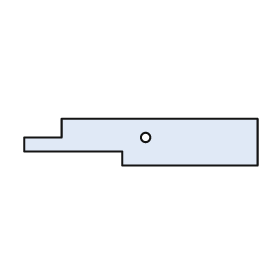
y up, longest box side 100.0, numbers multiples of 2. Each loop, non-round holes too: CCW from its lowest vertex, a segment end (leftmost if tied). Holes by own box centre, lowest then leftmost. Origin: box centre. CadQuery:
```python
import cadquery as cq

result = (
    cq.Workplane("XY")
    .moveTo(-8.0, -10.0)
    .lineTo(50.0, -10.0)
    .lineTo(50.0, 10.0)
    .lineTo(-34.0, 10.0)
    .lineTo(-34.0, 2.0)
    .lineTo(-50.0, 2.0)
    .lineTo(-50.0, -4.0)
    .lineTo(-8.0, -4.0)
    .close()
    .moveTo(2.0, 2.0)
    .circle(2.0)
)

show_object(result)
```